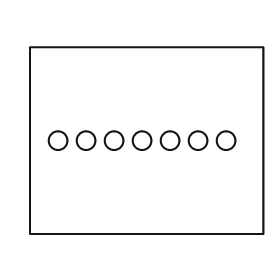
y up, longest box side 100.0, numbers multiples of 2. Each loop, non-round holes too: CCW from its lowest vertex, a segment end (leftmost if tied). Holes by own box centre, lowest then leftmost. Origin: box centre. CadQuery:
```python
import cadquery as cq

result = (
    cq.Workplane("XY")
    .moveTo(-50.0, -40.0)
    .lineTo(50.0, -40.0)
    .lineTo(50.0, 40.0)
    .lineTo(-50.0, 40.0)
    .close()
    .moveTo(-38.0, 0.0)
    .circle(4.0)
    .moveTo(-26.0, 0.0)
    .circle(4.0)
    .moveTo(-14.0, 0.0)
    .circle(4.0)
    .moveTo(-2.0, 0.0)
    .circle(4.0)
    .moveTo(10.0, 0.0)
    .circle(4.0)
    .moveTo(22.0, 0.0)
    .circle(4.0)
    .moveTo(34.0, 0.0)
    .circle(4.0)
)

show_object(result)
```